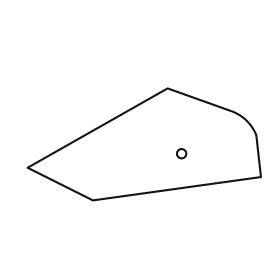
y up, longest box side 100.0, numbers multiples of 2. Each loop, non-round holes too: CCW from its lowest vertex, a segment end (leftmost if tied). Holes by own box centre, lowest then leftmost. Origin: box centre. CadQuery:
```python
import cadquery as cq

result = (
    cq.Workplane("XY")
    .moveTo(-22.0, -24.0)
    .lineTo(50.0, -14.0)
    .lineTo(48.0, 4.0)
    .threePointArc((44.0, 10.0), (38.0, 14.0))
    .lineTo(10.0, 24.0)
    .lineTo(-50.0, -10.0)
    .close()
    .moveTo(16.0, -4.0)
    .circle(2.0)
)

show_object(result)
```